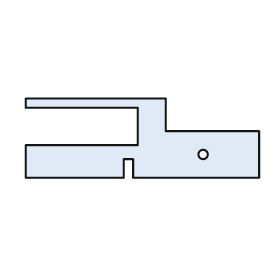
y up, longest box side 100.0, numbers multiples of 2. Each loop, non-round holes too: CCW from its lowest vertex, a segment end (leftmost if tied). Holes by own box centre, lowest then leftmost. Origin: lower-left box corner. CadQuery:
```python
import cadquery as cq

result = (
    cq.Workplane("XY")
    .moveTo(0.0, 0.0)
    .lineTo(42.0, 0.0)
    .lineTo(42.0, 8.0)
    .lineTo(46.0, 8.0)
    .lineTo(46.0, 0.0)
    .lineTo(100.0, 0.0)
    .lineTo(100.0, 20.0)
    .lineTo(60.0, 20.0)
    .lineTo(60.0, 34.0)
    .lineTo(0.0, 34.0)
    .lineTo(0.0, 30.0)
    .lineTo(48.0, 30.0)
    .lineTo(48.0, 14.0)
    .lineTo(0.0, 14.0)
    .close()
    .moveTo(76.0, 10.0)
    .circle(2.0)
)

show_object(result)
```